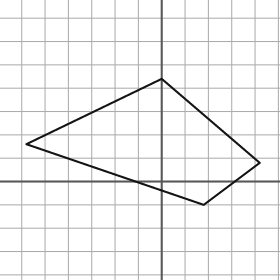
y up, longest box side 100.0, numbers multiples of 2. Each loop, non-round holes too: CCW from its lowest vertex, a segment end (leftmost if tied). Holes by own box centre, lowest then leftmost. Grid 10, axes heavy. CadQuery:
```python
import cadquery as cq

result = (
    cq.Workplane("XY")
    .moveTo(18.0, -10.0)
    .lineTo(42.0, 8.0)
    .lineTo(0.0, 44.0)
    .lineTo(-58.0, 16.0)
    .close()
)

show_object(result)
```